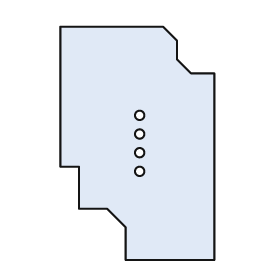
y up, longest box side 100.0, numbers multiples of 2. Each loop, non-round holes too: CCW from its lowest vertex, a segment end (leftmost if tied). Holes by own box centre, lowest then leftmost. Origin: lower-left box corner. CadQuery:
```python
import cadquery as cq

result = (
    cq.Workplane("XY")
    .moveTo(28.0, 0.0)
    .lineTo(66.0, 0.0)
    .lineTo(66.0, 80.0)
    .lineTo(56.0, 80.0)
    .lineTo(50.0, 86.0)
    .lineTo(50.0, 94.0)
    .lineTo(44.0, 100.0)
    .lineTo(0.0, 100.0)
    .lineTo(0.0, 40.0)
    .lineTo(8.0, 40.0)
    .lineTo(8.0, 22.0)
    .lineTo(20.0, 22.0)
    .lineTo(28.0, 14.0)
    .close()
    .moveTo(34.0, 38.0)
    .circle(2.0)
    .moveTo(34.0, 46.0)
    .circle(2.0)
    .moveTo(34.0, 54.0)
    .circle(2.0)
    .moveTo(34.0, 62.0)
    .circle(2.0)
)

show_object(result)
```